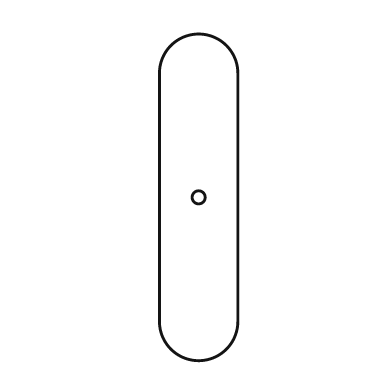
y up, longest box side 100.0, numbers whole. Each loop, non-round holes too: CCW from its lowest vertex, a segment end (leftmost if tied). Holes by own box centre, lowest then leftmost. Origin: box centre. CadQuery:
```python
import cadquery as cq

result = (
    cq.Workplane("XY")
    .moveTo(-12.0, -38.0)
    .threePointArc((0.0, -50.0), (12.0, -38.0))
    .lineTo(12.0, 38.0)
    .threePointArc((0.0, 50.0), (-12.0, 38.0))
    .close()
    .moveTo(0.0, 0.0)
    .circle(2.0)
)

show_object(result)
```